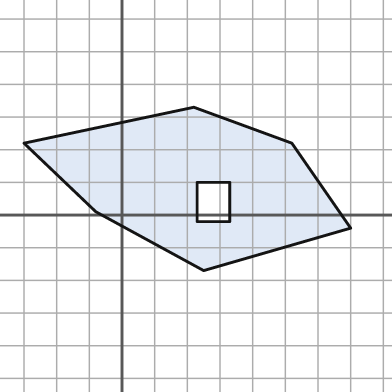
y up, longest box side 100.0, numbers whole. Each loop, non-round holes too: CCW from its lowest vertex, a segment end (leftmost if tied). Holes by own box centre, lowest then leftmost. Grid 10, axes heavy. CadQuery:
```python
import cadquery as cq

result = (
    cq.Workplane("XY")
    .moveTo(25.0, -17.0)
    .lineTo(70.0, -4.0)
    .lineTo(52.0, 22.0)
    .lineTo(22.0, 33.0)
    .lineTo(-30.0, 22.0)
    .lineTo(-8.0, 1.0)
    .close()
    .moveTo(23.0, -2.0)
    .lineTo(33.0, -2.0)
    .lineTo(33.0, 10.0)
    .lineTo(23.0, 10.0)
    .close()
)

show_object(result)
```